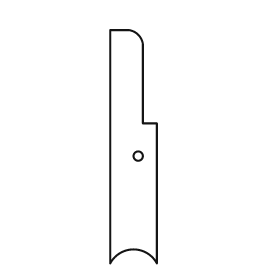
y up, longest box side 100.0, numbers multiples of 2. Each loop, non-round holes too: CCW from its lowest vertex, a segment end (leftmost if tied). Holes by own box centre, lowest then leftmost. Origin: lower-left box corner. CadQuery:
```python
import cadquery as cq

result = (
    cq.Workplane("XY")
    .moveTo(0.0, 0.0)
    .threePointArc((10.0, 6.0), (20.0, 0.0))
    .lineTo(20.0, 60.0)
    .lineTo(14.0, 60.0)
    .lineTo(14.0, 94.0)
    .threePointArc((12.0, 98.0), (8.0, 100.0))
    .lineTo(0.0, 100.0)
    .close()
    .moveTo(12.0, 46.0)
    .circle(2.0)
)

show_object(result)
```